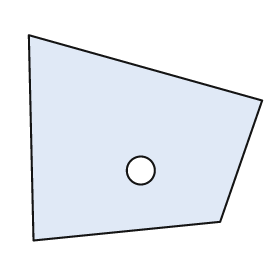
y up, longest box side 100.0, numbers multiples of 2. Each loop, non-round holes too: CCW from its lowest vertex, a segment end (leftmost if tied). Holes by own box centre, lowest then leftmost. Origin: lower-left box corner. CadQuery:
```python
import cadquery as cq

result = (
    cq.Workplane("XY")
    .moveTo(2.0, 0.0)
    .lineTo(82.0, 8.0)
    .lineTo(100.0, 60.0)
    .lineTo(0.0, 88.0)
    .close()
    .moveTo(48.0, 30.0)
    .circle(6.0)
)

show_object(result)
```